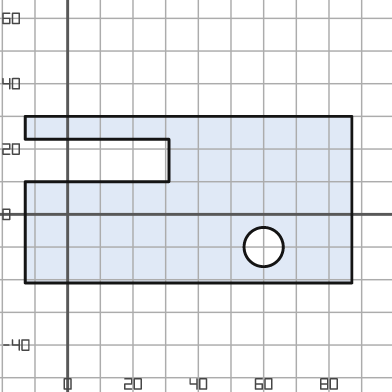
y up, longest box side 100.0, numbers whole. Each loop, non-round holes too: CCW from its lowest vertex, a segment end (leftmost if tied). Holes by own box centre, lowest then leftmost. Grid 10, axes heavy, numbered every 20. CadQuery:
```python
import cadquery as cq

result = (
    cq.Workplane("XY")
    .moveTo(-13.0, -21.0)
    .lineTo(87.0, -21.0)
    .lineTo(87.0, 30.0)
    .lineTo(-13.0, 30.0)
    .lineTo(-13.0, 23.0)
    .lineTo(31.0, 23.0)
    .lineTo(31.0, 10.0)
    .lineTo(-13.0, 10.0)
    .close()
    .moveTo(60.0, -10.0)
    .circle(6.0)
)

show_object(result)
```